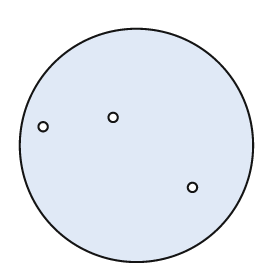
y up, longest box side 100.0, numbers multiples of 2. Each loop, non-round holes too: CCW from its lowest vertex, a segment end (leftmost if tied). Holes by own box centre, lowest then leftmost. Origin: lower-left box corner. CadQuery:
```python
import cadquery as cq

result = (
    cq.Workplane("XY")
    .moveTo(50.0, 50.0)
    .circle(50.0)
    .moveTo(74.0, 32.0)
    .circle(2.0)
    .moveTo(10.0, 58.0)
    .circle(2.0)
    .moveTo(40.0, 62.0)
    .circle(2.0)
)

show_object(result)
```